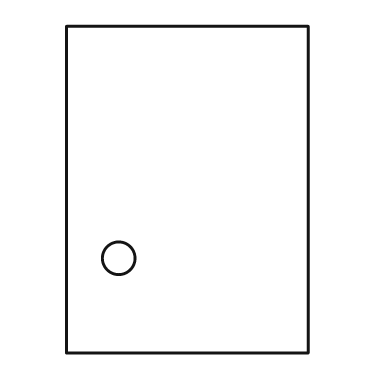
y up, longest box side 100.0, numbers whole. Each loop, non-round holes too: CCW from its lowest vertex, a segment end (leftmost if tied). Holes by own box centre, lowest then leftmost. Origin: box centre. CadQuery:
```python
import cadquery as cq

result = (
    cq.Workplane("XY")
    .moveTo(-37.0, -50.0)
    .lineTo(37.0, -50.0)
    .lineTo(37.0, 50.0)
    .lineTo(-37.0, 50.0)
    .close()
    .moveTo(-21.0, -21.0)
    .circle(5.0)
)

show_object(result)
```